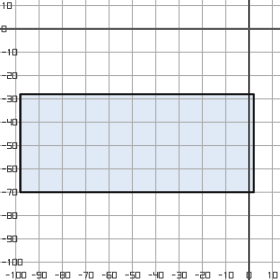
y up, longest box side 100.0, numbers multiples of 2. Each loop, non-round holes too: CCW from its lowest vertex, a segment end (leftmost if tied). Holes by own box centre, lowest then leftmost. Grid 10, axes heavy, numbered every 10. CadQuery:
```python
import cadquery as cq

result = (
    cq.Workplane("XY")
    .moveTo(-98.0, -70.0)
    .lineTo(2.0, -70.0)
    .lineTo(2.0, -28.0)
    .lineTo(-98.0, -28.0)
    .close()
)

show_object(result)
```